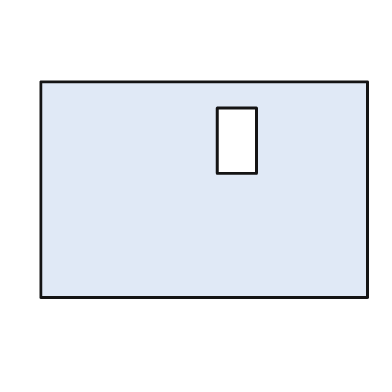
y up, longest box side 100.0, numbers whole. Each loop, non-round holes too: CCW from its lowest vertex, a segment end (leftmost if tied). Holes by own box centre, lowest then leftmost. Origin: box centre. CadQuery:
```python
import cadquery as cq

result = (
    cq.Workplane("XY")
    .moveTo(-50.0, -33.0)
    .lineTo(50.0, -33.0)
    .lineTo(50.0, 33.0)
    .lineTo(-50.0, 33.0)
    .close()
    .moveTo(4.0, 5.0)
    .lineTo(16.0, 5.0)
    .lineTo(16.0, 25.0)
    .lineTo(4.0, 25.0)
    .close()
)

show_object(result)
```